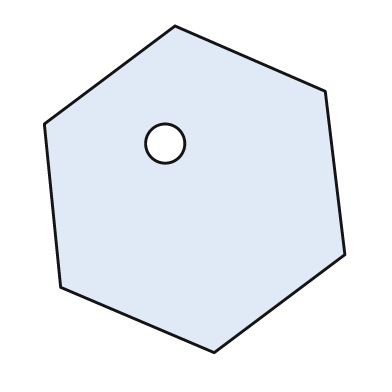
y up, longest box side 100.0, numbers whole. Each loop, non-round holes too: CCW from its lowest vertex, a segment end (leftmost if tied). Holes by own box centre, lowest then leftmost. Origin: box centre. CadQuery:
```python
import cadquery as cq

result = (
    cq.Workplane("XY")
    .moveTo(6.0, -50.0)
    .lineTo(46.0, -20.0)
    .lineTo(40.0, 30.0)
    .lineTo(-6.0, 50.0)
    .lineTo(-46.0, 20.0)
    .lineTo(-41.0, -30.0)
    .close()
    .moveTo(-9.0, 14.0)
    .circle(6.0)
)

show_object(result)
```